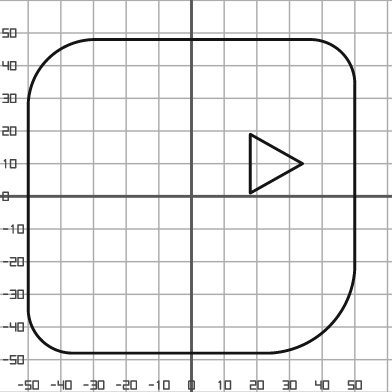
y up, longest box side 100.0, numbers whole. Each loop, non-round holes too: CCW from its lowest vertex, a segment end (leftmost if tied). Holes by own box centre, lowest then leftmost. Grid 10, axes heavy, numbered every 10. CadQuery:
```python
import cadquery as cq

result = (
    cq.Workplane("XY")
    .moveTo(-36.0, -48.0)
    .lineTo(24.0, -48.0)
    .threePointArc((42.0, -40.0), (50.0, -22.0))
    .lineTo(50.0, 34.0)
    .threePointArc((46.0, 44.0), (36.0, 48.0))
    .lineTo(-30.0, 48.0)
    .threePointArc((-44.0, 42.0), (-50.0, 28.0))
    .lineTo(-50.0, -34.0)
    .threePointArc((-46.0, -44.0), (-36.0, -48.0))
    .close()
    .moveTo(18.0, 1.0)
    .lineTo(34.0, 10.0)
    .lineTo(18.0, 19.0)
    .close()
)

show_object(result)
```